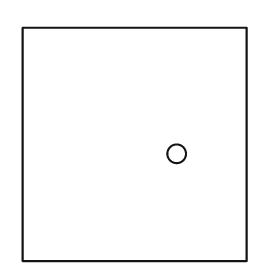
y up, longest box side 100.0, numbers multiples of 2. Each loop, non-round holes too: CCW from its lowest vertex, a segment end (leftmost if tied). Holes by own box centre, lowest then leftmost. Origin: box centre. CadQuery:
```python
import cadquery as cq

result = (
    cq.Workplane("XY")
    .moveTo(-48.0, -50.0)
    .lineTo(48.0, -50.0)
    .lineTo(48.0, 50.0)
    .lineTo(-48.0, 50.0)
    .close()
    .moveTo(18.0, -4.0)
    .circle(4.0)
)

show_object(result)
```